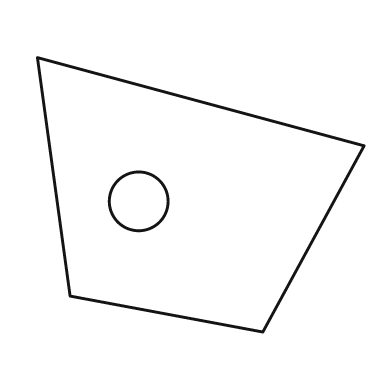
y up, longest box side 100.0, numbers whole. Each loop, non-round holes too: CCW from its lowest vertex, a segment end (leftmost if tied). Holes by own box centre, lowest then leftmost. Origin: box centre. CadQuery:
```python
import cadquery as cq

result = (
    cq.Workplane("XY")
    .moveTo(19.0, -42.0)
    .lineTo(50.0, 15.0)
    .lineTo(-50.0, 42.0)
    .lineTo(-40.0, -31.0)
    .close()
    .moveTo(-19.0, -2.0)
    .circle(9.0)
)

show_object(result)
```